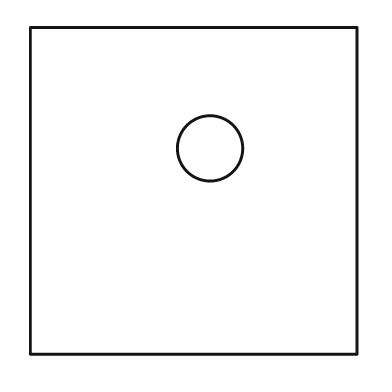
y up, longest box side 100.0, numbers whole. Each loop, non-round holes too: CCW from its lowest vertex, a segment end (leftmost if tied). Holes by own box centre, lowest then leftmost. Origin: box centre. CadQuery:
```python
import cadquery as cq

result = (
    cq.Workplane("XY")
    .moveTo(-50.0, -50.0)
    .lineTo(50.0, -50.0)
    .lineTo(50.0, 50.0)
    .lineTo(-50.0, 50.0)
    .close()
    .moveTo(5.0, 13.0)
    .circle(10.0)
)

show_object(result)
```